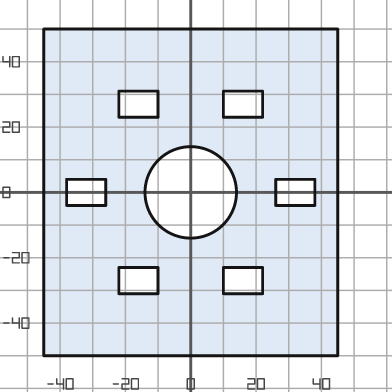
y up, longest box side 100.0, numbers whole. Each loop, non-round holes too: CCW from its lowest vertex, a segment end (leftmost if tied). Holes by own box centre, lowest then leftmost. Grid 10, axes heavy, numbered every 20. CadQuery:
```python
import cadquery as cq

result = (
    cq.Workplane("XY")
    .moveTo(-45.0, -50.0)
    .lineTo(45.0, -50.0)
    .lineTo(45.0, 50.0)
    .lineTo(-45.0, 50.0)
    .close()
    .moveTo(-22.0, -31.0)
    .lineTo(-10.0, -31.0)
    .lineTo(-10.0, -23.0)
    .lineTo(-22.0, -23.0)
    .close()
    .moveTo(10.0, -31.0)
    .lineTo(22.0, -31.0)
    .lineTo(22.0, -23.0)
    .lineTo(10.0, -23.0)
    .close()
    .moveTo(-38.0, -4.0)
    .lineTo(-26.0, -4.0)
    .lineTo(-26.0, 4.0)
    .lineTo(-38.0, 4.0)
    .close()
    .moveTo(0.0, 0.0)
    .circle(14.0)
    .moveTo(26.0, -4.0)
    .lineTo(38.0, -4.0)
    .lineTo(38.0, 4.0)
    .lineTo(26.0, 4.0)
    .close()
    .moveTo(-22.0, 23.0)
    .lineTo(-10.0, 23.0)
    .lineTo(-10.0, 31.0)
    .lineTo(-22.0, 31.0)
    .close()
    .moveTo(10.0, 23.0)
    .lineTo(22.0, 23.0)
    .lineTo(22.0, 31.0)
    .lineTo(10.0, 31.0)
    .close()
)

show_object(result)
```